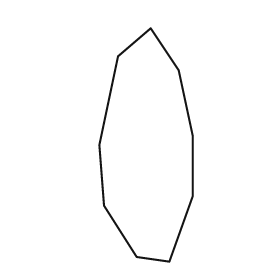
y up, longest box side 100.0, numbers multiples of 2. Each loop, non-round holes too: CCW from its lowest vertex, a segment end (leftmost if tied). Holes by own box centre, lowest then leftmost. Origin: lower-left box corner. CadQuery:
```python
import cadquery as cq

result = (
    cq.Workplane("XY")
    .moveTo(30.0, 0.0)
    .lineTo(40.0, 28.0)
    .lineTo(40.0, 54.0)
    .lineTo(34.0, 82.0)
    .lineTo(22.0, 100.0)
    .lineTo(8.0, 88.0)
    .lineTo(0.0, 50.0)
    .lineTo(2.0, 24.0)
    .lineTo(16.0, 2.0)
    .close()
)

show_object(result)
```